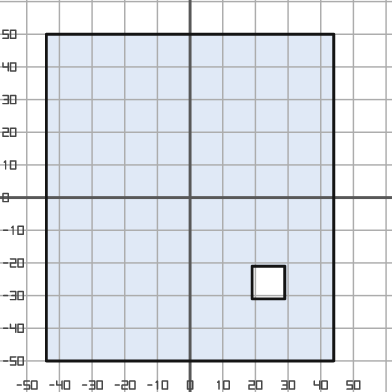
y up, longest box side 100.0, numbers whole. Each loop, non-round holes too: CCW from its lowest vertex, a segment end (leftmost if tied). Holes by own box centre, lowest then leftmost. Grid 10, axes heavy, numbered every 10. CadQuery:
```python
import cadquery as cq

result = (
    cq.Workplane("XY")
    .moveTo(-44.0, -50.0)
    .lineTo(44.0, -50.0)
    .lineTo(44.0, 50.0)
    .lineTo(-44.0, 50.0)
    .close()
    .moveTo(19.0, -31.0)
    .lineTo(29.0, -31.0)
    .lineTo(29.0, -21.0)
    .lineTo(19.0, -21.0)
    .close()
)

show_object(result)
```